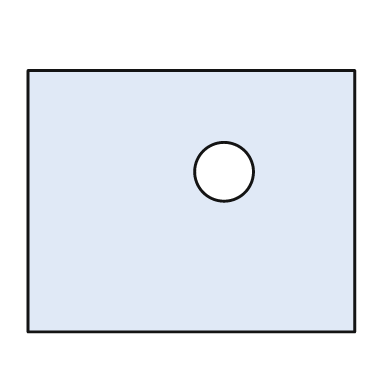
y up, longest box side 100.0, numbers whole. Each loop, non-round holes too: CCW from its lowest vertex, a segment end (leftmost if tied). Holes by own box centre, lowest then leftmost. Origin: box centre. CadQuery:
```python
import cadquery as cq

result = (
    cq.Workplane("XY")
    .moveTo(-50.0, -40.0)
    .lineTo(50.0, -40.0)
    .lineTo(50.0, 40.0)
    .lineTo(-50.0, 40.0)
    .close()
    .moveTo(10.0, 9.0)
    .circle(9.0)
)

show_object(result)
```